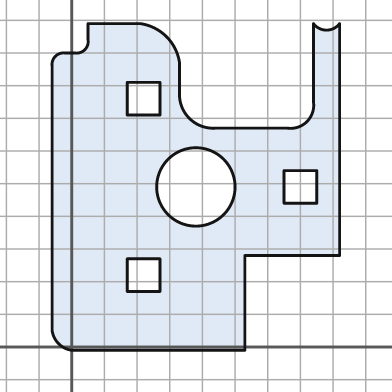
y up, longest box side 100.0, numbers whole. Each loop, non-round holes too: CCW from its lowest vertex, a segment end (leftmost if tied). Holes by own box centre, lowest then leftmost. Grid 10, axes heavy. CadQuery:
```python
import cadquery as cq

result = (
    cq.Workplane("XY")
    .moveTo(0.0, -1.0)
    .lineTo(53.0, -1.0)
    .lineTo(53.0, 28.0)
    .lineTo(82.0, 28.0)
    .lineTo(82.0, 99.0)
    .threePointArc((78.0, 97.0), (74.0, 99.0))
    .lineTo(74.0, 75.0)
    .threePointArc((72.0, 69.0), (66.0, 67.0))
    .lineTo(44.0, 67.0)
    .threePointArc((36.0, 70.0), (33.0, 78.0))
    .lineTo(33.0, 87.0)
    .threePointArc((29.0, 95.0), (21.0, 99.0))
    .lineTo(5.0, 99.0)
    .lineTo(5.0, 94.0)
    .threePointArc((4.0, 91.0), (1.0, 90.0))
    .lineTo(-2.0, 90.0)
    .threePointArc((-5.0, 89.0), (-6.0, 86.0))
    .lineTo(-6.0, 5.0)
    .threePointArc((-4.0, 1.0), (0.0, -1.0))
    .close()
    .moveTo(17.0, 17.0)
    .lineTo(27.0, 17.0)
    .lineTo(27.0, 27.0)
    .lineTo(17.0, 27.0)
    .close()
    .moveTo(38.0, 49.0)
    .circle(12.0)
    .moveTo(65.0, 44.0)
    .lineTo(75.0, 44.0)
    .lineTo(75.0, 54.0)
    .lineTo(65.0, 54.0)
    .close()
    .moveTo(17.0, 71.0)
    .lineTo(27.0, 71.0)
    .lineTo(27.0, 81.0)
    .lineTo(17.0, 81.0)
    .close()
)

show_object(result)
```